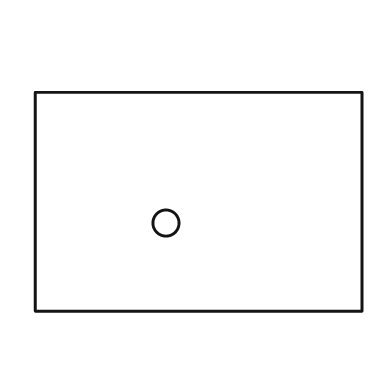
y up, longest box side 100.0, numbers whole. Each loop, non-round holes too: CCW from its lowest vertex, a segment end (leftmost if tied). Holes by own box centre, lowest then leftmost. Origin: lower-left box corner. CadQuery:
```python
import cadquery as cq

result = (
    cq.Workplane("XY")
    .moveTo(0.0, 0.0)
    .lineTo(100.0, 0.0)
    .lineTo(100.0, 67.0)
    .lineTo(0.0, 67.0)
    .close()
    .moveTo(40.0, 27.0)
    .circle(4.0)
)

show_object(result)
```